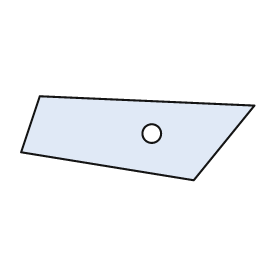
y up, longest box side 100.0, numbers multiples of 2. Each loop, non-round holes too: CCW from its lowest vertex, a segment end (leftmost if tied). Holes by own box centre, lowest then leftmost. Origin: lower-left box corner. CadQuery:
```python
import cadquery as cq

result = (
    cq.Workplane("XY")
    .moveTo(74.0, 0.0)
    .lineTo(100.0, 32.0)
    .lineTo(8.0, 36.0)
    .lineTo(0.0, 12.0)
    .close()
    .moveTo(56.0, 20.0)
    .circle(4.0)
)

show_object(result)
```